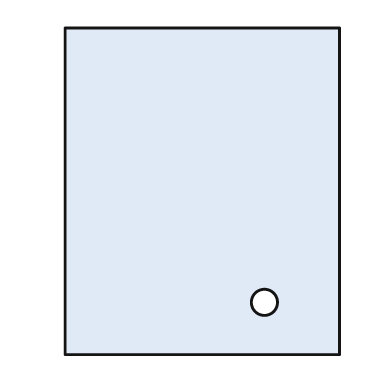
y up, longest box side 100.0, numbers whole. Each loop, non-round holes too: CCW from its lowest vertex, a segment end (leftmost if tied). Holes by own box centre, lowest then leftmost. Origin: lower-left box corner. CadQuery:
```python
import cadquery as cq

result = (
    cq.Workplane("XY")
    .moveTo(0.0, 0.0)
    .lineTo(84.0, 0.0)
    .lineTo(84.0, 100.0)
    .lineTo(0.0, 100.0)
    .close()
    .moveTo(61.0, 16.0)
    .circle(4.0)
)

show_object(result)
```